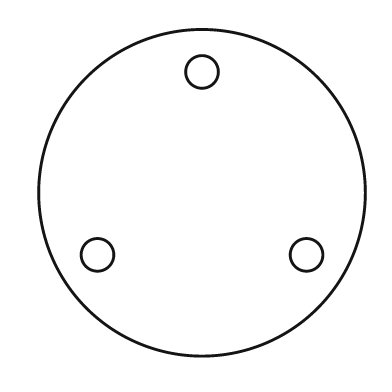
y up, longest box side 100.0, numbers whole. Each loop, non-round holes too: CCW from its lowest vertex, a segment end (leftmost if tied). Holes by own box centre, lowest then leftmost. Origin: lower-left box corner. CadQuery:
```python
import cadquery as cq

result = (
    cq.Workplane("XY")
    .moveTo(50.0, 50.0)
    .circle(50.0)
    .moveTo(18.0, 31.0)
    .circle(5.0)
    .moveTo(82.0, 31.0)
    .circle(5.0)
    .moveTo(50.0, 87.0)
    .circle(5.0)
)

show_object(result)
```